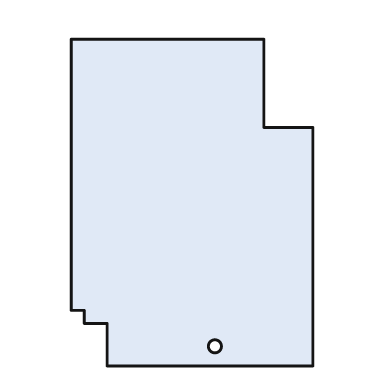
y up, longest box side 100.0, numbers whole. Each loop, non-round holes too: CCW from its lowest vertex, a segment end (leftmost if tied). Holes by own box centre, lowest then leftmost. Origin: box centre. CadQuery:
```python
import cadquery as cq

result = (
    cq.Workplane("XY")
    .moveTo(-26.0, -50.0)
    .lineTo(37.0, -50.0)
    .lineTo(37.0, 23.0)
    .lineTo(22.0, 23.0)
    .lineTo(22.0, 50.0)
    .lineTo(-37.0, 50.0)
    .lineTo(-37.0, -33.0)
    .lineTo(-33.0, -33.0)
    .lineTo(-33.0, -37.0)
    .lineTo(-26.0, -37.0)
    .close()
    .moveTo(7.0, -44.0)
    .circle(2.0)
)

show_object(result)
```